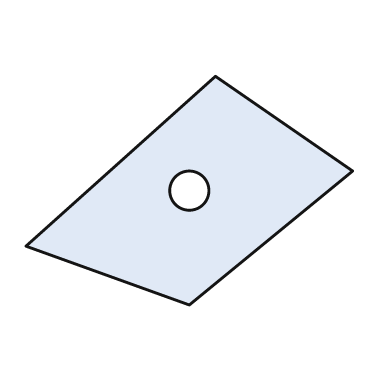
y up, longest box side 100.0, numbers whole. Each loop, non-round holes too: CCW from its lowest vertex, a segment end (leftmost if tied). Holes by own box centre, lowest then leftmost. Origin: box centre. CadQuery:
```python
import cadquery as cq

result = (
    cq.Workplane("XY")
    .moveTo(0.0, -35.0)
    .lineTo(50.0, 6.0)
    .lineTo(8.0, 35.0)
    .lineTo(-50.0, -17.0)
    .close()
    .moveTo(0.0, 0.0)
    .circle(6.0)
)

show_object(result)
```